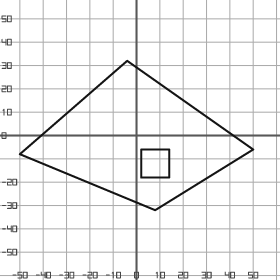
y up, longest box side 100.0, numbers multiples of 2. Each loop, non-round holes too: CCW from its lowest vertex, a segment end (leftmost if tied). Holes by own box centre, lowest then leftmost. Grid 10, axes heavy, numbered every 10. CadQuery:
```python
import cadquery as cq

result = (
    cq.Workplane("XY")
    .moveTo(8.0, -32.0)
    .lineTo(50.0, -6.0)
    .lineTo(-4.0, 32.0)
    .lineTo(-50.0, -8.0)
    .close()
    .moveTo(2.0, -18.0)
    .lineTo(14.0, -18.0)
    .lineTo(14.0, -6.0)
    .lineTo(2.0, -6.0)
    .close()
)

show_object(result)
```